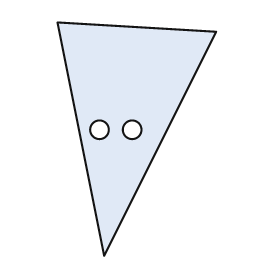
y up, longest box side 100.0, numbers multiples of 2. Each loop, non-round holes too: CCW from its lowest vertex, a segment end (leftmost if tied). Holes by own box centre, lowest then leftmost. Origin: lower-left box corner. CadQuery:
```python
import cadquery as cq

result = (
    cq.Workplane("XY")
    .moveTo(20.0, 0.0)
    .lineTo(68.0, 96.0)
    .lineTo(0.0, 100.0)
    .close()
    .moveTo(18.0, 54.0)
    .circle(4.0)
    .moveTo(32.0, 54.0)
    .circle(4.0)
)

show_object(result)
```